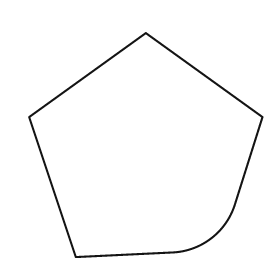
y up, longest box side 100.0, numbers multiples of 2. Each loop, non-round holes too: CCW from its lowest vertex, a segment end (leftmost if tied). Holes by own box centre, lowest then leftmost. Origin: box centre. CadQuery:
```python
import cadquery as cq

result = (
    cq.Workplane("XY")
    .moveTo(-30.0, -48.0)
    .lineTo(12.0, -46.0)
    .threePointArc((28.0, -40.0), (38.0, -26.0))
    .lineTo(50.0, 12.0)
    .lineTo(0.0, 48.0)
    .lineTo(-50.0, 12.0)
    .close()
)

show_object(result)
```